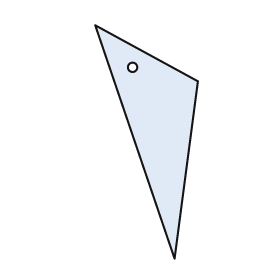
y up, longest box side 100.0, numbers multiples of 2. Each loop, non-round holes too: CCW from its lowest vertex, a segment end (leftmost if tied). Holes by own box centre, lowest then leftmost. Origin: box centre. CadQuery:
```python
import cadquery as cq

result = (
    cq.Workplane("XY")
    .moveTo(12.0, -50.0)
    .lineTo(22.0, 26.0)
    .lineTo(-22.0, 50.0)
    .close()
    .moveTo(-6.0, 32.0)
    .circle(2.0)
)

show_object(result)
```